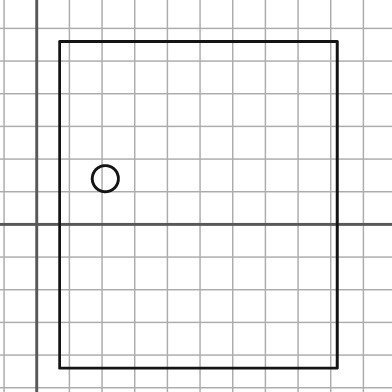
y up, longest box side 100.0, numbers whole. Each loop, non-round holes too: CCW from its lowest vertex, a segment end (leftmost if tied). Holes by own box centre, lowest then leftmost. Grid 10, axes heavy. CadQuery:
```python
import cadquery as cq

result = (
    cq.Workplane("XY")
    .moveTo(7.0, -44.0)
    .lineTo(92.0, -44.0)
    .lineTo(92.0, 56.0)
    .lineTo(7.0, 56.0)
    .close()
    .moveTo(21.0, 14.0)
    .circle(4.0)
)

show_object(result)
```